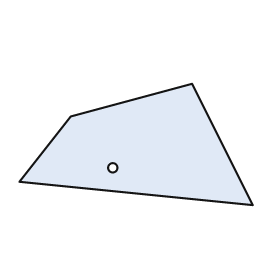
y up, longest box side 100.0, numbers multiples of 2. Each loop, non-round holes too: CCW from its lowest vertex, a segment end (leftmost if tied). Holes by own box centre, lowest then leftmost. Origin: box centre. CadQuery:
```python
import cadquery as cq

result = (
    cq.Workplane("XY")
    .moveTo(50.0, -26.0)
    .lineTo(24.0, 26.0)
    .lineTo(-28.0, 12.0)
    .lineTo(-50.0, -16.0)
    .close()
    .moveTo(-10.0, -10.0)
    .circle(2.0)
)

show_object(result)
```